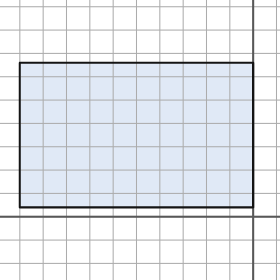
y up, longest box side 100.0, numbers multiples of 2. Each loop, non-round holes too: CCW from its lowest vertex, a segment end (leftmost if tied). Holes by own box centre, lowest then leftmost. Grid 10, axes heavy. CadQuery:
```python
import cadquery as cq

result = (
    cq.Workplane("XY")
    .moveTo(-100.0, 4.0)
    .lineTo(0.0, 4.0)
    .lineTo(0.0, 66.0)
    .lineTo(-100.0, 66.0)
    .close()
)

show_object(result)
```